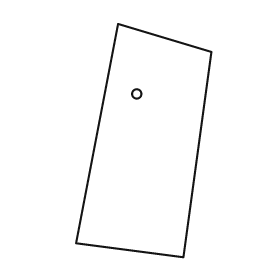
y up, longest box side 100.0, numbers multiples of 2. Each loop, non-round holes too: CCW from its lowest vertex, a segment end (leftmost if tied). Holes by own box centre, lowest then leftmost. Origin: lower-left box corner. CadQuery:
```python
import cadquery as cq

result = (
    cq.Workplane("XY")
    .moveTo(46.0, 0.0)
    .lineTo(58.0, 88.0)
    .lineTo(18.0, 100.0)
    .lineTo(0.0, 6.0)
    .close()
    .moveTo(26.0, 70.0)
    .circle(2.0)
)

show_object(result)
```